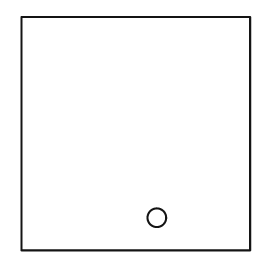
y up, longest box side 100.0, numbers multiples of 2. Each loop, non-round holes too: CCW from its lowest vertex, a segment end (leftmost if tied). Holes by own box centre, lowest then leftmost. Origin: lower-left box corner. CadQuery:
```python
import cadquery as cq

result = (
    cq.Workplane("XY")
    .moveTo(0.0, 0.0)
    .lineTo(98.0, 0.0)
    .lineTo(98.0, 100.0)
    .lineTo(0.0, 100.0)
    .close()
    .moveTo(58.0, 14.0)
    .circle(4.0)
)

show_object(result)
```